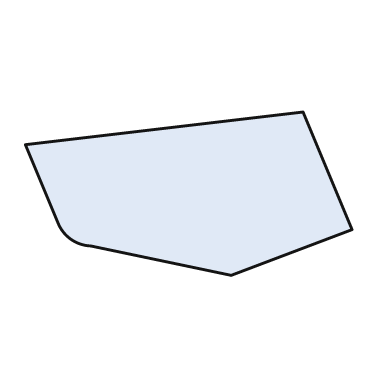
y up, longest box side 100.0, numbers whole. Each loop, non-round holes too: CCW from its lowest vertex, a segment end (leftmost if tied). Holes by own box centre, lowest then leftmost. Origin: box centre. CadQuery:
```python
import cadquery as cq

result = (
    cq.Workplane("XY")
    .moveTo(13.0, -25.0)
    .lineTo(50.0, -11.0)
    .lineTo(35.0, 25.0)
    .lineTo(-50.0, 15.0)
    .lineTo(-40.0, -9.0)
    .threePointArc((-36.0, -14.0), (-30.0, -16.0))
    .close()
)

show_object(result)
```